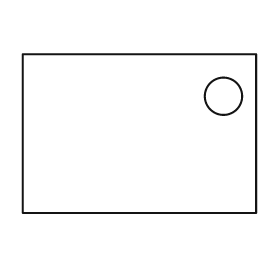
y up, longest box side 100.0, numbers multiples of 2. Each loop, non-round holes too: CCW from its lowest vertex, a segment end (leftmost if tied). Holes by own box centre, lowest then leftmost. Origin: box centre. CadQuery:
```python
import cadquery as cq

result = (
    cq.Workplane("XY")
    .moveTo(-50.0, -34.0)
    .lineTo(50.0, -34.0)
    .lineTo(50.0, 34.0)
    .lineTo(-50.0, 34.0)
    .close()
    .moveTo(36.0, 16.0)
    .circle(8.0)
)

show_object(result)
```